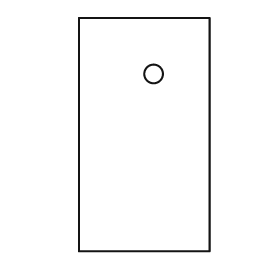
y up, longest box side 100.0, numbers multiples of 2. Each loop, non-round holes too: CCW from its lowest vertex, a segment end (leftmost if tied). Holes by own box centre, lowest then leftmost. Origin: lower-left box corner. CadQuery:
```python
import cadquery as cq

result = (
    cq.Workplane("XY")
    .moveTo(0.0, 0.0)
    .lineTo(56.0, 0.0)
    .lineTo(56.0, 100.0)
    .lineTo(0.0, 100.0)
    .close()
    .moveTo(32.0, 76.0)
    .circle(4.0)
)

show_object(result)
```